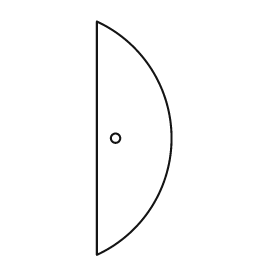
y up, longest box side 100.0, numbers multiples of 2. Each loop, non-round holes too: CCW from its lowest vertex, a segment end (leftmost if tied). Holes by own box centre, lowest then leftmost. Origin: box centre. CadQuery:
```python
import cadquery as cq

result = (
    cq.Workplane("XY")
    .moveTo(-16.0, -50.0)
    .threePointArc((16.0, 0.0), (-16.0, 50.0))
    .close()
    .moveTo(-8.0, 0.0)
    .circle(2.0)
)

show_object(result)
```